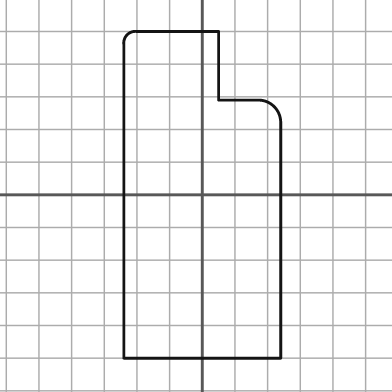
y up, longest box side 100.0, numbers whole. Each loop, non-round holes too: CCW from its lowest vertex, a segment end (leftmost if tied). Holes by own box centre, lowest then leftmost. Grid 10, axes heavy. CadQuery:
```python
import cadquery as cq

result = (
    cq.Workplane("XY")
    .moveTo(-24.0, -50.0)
    .lineTo(24.0, -50.0)
    .lineTo(24.0, 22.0)
    .threePointArc((22.0, 27.0), (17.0, 29.0))
    .lineTo(5.0, 29.0)
    .lineTo(5.0, 50.0)
    .lineTo(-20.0, 50.0)
    .threePointArc((-23.0, 49.0), (-24.0, 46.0))
    .close()
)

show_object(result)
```